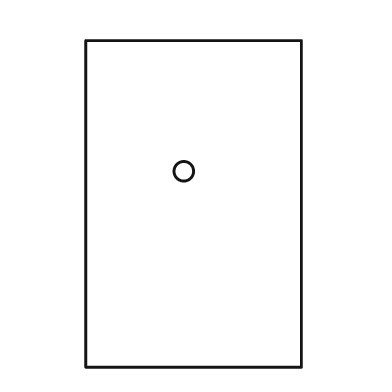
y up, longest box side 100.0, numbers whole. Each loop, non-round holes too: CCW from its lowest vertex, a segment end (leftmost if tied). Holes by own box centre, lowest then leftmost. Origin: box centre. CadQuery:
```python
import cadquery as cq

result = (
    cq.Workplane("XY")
    .moveTo(-33.0, -50.0)
    .lineTo(33.0, -50.0)
    .lineTo(33.0, 50.0)
    .lineTo(-33.0, 50.0)
    .close()
    .moveTo(-3.0, 10.0)
    .circle(3.0)
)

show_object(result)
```